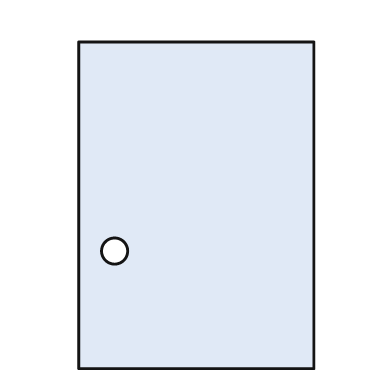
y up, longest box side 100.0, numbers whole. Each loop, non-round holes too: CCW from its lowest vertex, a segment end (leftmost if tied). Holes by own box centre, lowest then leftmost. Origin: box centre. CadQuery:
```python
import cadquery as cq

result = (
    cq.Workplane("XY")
    .moveTo(-36.0, -50.0)
    .lineTo(36.0, -50.0)
    .lineTo(36.0, 50.0)
    .lineTo(-36.0, 50.0)
    .close()
    .moveTo(-25.0, -14.0)
    .circle(4.0)
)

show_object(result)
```